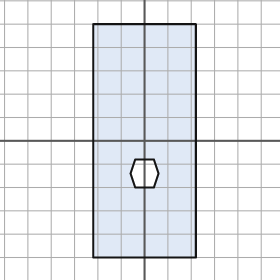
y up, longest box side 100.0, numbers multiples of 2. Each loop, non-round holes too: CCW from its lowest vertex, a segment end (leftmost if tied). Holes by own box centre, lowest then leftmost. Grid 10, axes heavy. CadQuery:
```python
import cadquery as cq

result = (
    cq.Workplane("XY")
    .moveTo(-22.0, -50.0)
    .lineTo(22.0, -50.0)
    .lineTo(22.0, 50.0)
    .lineTo(-22.0, 50.0)
    .close()
    .moveTo(-4.0, -20.0)
    .lineTo(4.0, -20.0)
    .lineTo(6.0, -14.0)
    .lineTo(4.0, -8.0)
    .lineTo(-4.0, -8.0)
    .lineTo(-6.0, -14.0)
    .close()
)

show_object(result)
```